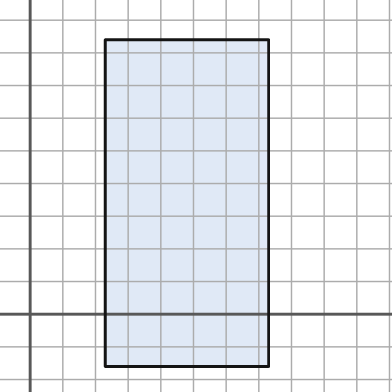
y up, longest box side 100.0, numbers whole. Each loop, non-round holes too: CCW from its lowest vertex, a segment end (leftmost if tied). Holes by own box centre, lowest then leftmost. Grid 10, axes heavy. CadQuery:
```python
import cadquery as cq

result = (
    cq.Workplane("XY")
    .moveTo(23.0, -16.0)
    .lineTo(73.0, -16.0)
    .lineTo(73.0, 84.0)
    .lineTo(23.0, 84.0)
    .close()
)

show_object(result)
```